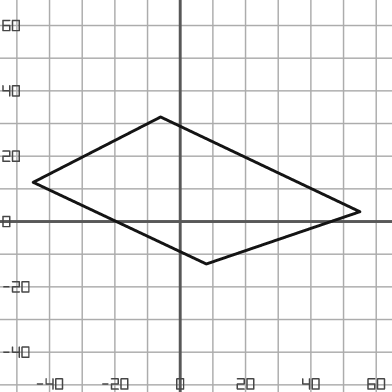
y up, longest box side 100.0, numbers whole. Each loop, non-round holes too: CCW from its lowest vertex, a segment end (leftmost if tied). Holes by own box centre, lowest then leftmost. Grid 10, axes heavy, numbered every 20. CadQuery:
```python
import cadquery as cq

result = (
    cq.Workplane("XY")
    .moveTo(8.0, -13.0)
    .lineTo(55.0, 3.0)
    .lineTo(-6.0, 32.0)
    .lineTo(-45.0, 12.0)
    .close()
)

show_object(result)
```